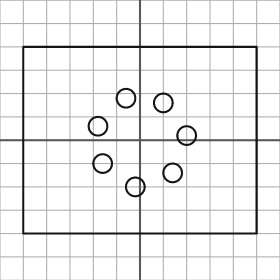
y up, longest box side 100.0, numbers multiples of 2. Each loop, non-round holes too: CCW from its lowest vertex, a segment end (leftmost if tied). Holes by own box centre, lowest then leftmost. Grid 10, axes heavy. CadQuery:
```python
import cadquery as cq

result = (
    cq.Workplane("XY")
    .moveTo(-50.0, -40.0)
    .lineTo(50.0, -40.0)
    .lineTo(50.0, 40.0)
    .lineTo(-50.0, 40.0)
    .close()
    .moveTo(-2.0, -20.0)
    .circle(4.0)
    .moveTo(14.0, -14.0)
    .circle(4.0)
    .moveTo(-16.0, -10.0)
    .circle(4.0)
    .moveTo(20.0, 2.0)
    .circle(4.0)
    .moveTo(-18.0, 6.0)
    .circle(4.0)
    .moveTo(10.0, 16.0)
    .circle(4.0)
    .moveTo(-6.0, 18.0)
    .circle(4.0)
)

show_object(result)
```